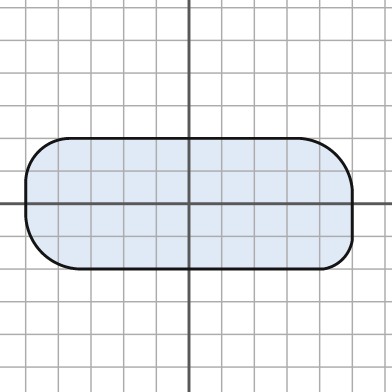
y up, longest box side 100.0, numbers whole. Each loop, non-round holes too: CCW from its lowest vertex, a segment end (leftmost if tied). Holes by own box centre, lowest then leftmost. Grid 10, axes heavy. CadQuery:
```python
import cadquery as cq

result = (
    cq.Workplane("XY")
    .moveTo(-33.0, -20.0)
    .lineTo(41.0, -20.0)
    .threePointArc((47.0, -17.0), (50.0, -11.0))
    .lineTo(50.0, 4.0)
    .threePointArc((45.0, 15.0), (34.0, 20.0))
    .lineTo(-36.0, 20.0)
    .threePointArc((-46.0, 16.0), (-50.0, 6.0))
    .lineTo(-50.0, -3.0)
    .threePointArc((-45.0, -15.0), (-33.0, -20.0))
    .close()
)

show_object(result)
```